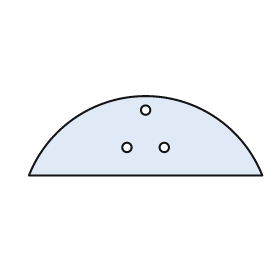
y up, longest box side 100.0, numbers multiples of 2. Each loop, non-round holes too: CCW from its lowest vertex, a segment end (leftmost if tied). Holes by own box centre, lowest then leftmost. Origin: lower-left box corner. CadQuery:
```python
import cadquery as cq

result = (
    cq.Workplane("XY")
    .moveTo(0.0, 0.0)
    .lineTo(100.0, 0.0)
    .threePointArc((50.0, 34.0), (0.0, 0.0))
    .close()
    .moveTo(42.0, 12.0)
    .circle(2.0)
    .moveTo(58.0, 12.0)
    .circle(2.0)
    .moveTo(50.0, 28.0)
    .circle(2.0)
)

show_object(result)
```